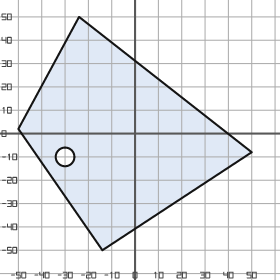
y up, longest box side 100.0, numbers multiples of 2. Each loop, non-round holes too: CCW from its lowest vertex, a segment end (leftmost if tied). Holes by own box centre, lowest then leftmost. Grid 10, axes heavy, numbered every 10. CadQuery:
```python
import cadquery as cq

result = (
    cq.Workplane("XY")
    .moveTo(-14.0, -50.0)
    .lineTo(50.0, -8.0)
    .lineTo(-24.0, 50.0)
    .lineTo(-50.0, 2.0)
    .close()
    .moveTo(-30.0, -10.0)
    .circle(4.0)
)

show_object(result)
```